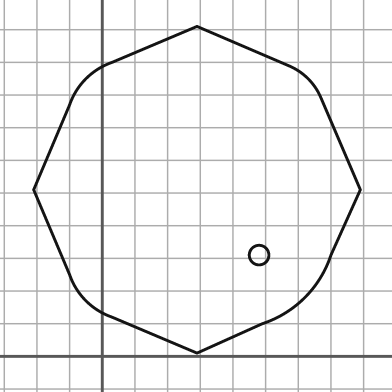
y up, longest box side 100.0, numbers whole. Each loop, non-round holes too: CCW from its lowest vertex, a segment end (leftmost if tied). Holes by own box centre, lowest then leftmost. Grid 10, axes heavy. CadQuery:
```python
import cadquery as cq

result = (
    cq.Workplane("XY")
    .moveTo(29.0, 1.0)
    .lineTo(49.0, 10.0)
    .threePointArc((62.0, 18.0), (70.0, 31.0))
    .lineTo(79.0, 51.0)
    .lineTo(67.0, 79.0)
    .threePointArc((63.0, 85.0), (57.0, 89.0))
    .lineTo(29.0, 101.0)
    .lineTo(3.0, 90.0)
    .threePointArc((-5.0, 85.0), (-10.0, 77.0))
    .lineTo(-21.0, 51.0)
    .lineTo(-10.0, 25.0)
    .threePointArc((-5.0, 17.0), (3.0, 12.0))
    .close()
    .moveTo(48.0, 31.0)
    .circle(3.0)
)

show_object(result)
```